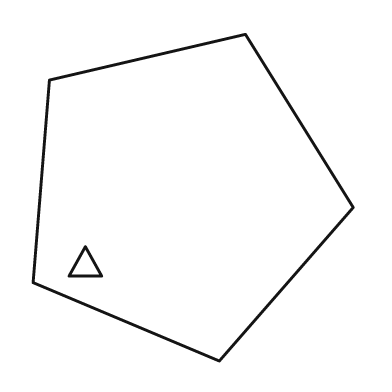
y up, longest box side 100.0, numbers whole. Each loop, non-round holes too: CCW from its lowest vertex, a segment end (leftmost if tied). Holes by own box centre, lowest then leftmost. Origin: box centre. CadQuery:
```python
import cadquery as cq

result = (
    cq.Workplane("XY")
    .moveTo(8.0, -50.0)
    .lineTo(49.0, -3.0)
    .lineTo(16.0, 50.0)
    .lineTo(-44.0, 36.0)
    .lineTo(-49.0, -26.0)
    .close()
    .moveTo(-38.0, -24.0)
    .lineTo(-28.0, -24.0)
    .lineTo(-33.0, -15.0)
    .close()
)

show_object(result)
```